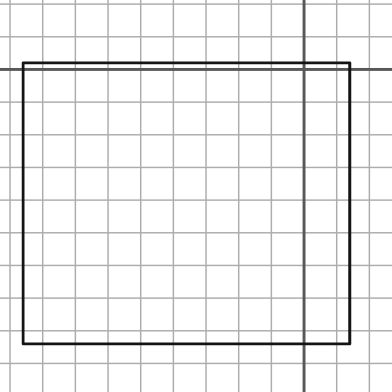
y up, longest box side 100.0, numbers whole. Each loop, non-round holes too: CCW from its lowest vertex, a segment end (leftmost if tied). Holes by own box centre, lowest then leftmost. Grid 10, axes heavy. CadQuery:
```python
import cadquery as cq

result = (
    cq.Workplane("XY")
    .moveTo(-86.0, -84.0)
    .lineTo(14.0, -84.0)
    .lineTo(14.0, 2.0)
    .lineTo(-86.0, 2.0)
    .close()
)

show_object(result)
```